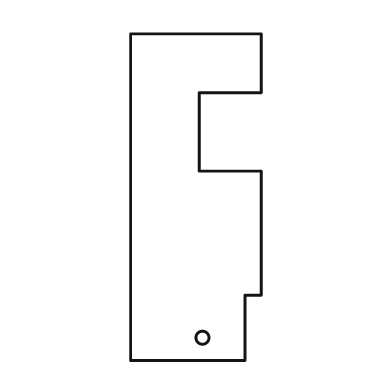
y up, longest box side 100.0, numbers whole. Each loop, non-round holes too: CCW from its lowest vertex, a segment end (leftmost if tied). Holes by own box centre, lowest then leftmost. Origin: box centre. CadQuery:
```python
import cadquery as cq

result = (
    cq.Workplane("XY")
    .moveTo(-20.0, -50.0)
    .lineTo(15.0, -50.0)
    .lineTo(15.0, -30.0)
    .lineTo(20.0, -30.0)
    .lineTo(20.0, 8.0)
    .lineTo(1.0, 8.0)
    .lineTo(1.0, 32.0)
    .lineTo(20.0, 32.0)
    .lineTo(20.0, 50.0)
    .lineTo(-20.0, 50.0)
    .close()
    .moveTo(2.0, -43.0)
    .circle(2.0)
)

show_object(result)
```